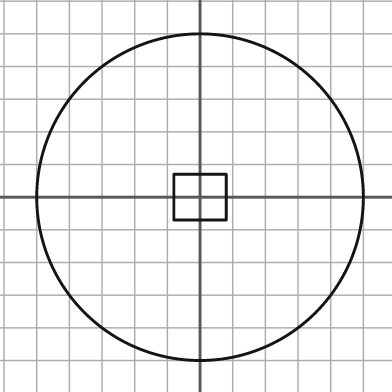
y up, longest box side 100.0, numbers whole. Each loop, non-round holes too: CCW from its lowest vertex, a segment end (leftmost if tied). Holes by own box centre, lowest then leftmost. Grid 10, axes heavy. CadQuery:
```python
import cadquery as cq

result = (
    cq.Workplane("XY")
    .moveTo(0.0, 0.0)
    .circle(50.0)
    .moveTo(-8.0, -7.0)
    .lineTo(8.0, -7.0)
    .lineTo(8.0, 7.0)
    .lineTo(-8.0, 7.0)
    .close()
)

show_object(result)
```